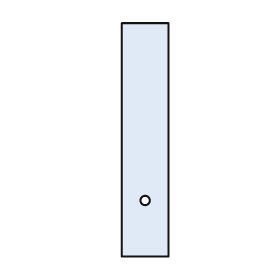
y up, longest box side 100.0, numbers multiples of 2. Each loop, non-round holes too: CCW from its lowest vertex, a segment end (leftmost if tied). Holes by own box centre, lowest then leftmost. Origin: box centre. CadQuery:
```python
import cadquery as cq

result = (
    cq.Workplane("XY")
    .moveTo(-10.0, -50.0)
    .lineTo(10.0, -50.0)
    .lineTo(10.0, 50.0)
    .lineTo(-10.0, 50.0)
    .close()
    .moveTo(0.0, -26.0)
    .circle(2.0)
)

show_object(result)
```